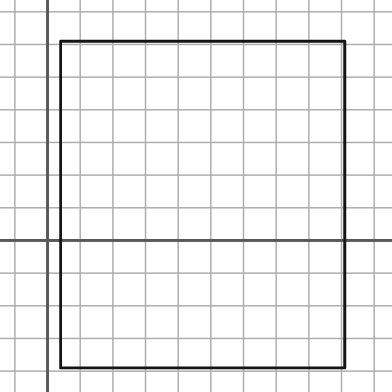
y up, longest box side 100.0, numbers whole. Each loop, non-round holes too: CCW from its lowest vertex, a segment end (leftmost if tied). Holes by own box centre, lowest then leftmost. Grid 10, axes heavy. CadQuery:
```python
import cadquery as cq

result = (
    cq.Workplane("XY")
    .moveTo(4.0, -39.0)
    .lineTo(91.0, -39.0)
    .lineTo(91.0, 61.0)
    .lineTo(4.0, 61.0)
    .close()
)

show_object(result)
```